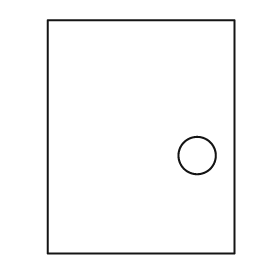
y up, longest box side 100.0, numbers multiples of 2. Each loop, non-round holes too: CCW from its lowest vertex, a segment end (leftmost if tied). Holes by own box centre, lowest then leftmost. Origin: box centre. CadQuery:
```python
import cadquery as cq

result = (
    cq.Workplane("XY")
    .moveTo(-40.0, -50.0)
    .lineTo(40.0, -50.0)
    .lineTo(40.0, 50.0)
    .lineTo(-40.0, 50.0)
    .close()
    .moveTo(24.0, -8.0)
    .circle(8.0)
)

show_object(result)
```